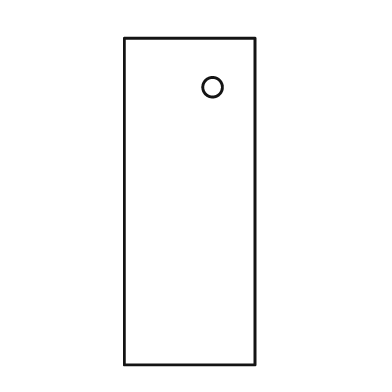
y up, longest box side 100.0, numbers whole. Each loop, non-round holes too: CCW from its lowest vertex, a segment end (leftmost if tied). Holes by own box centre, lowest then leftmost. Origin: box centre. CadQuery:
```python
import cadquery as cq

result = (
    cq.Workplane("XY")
    .moveTo(-20.0, -50.0)
    .lineTo(20.0, -50.0)
    .lineTo(20.0, 50.0)
    .lineTo(-20.0, 50.0)
    .close()
    .moveTo(7.0, 35.0)
    .circle(3.0)
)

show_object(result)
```